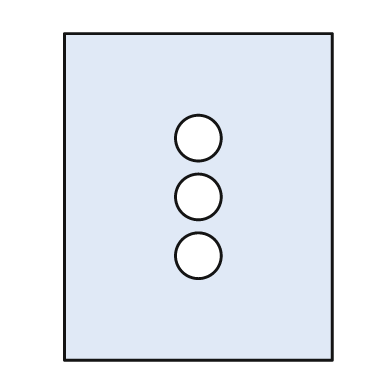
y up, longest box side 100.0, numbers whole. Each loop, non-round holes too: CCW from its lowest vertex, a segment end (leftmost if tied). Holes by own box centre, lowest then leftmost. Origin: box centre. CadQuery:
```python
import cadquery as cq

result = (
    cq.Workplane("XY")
    .moveTo(-41.0, -50.0)
    .lineTo(41.0, -50.0)
    .lineTo(41.0, 50.0)
    .lineTo(-41.0, 50.0)
    .close()
    .moveTo(0.0, -18.0)
    .circle(7.0)
    .moveTo(0.0, 0.0)
    .circle(7.0)
    .moveTo(0.0, 18.0)
    .circle(7.0)
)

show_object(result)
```